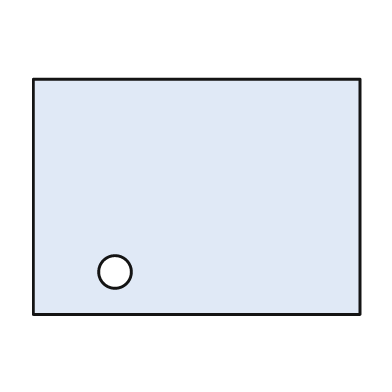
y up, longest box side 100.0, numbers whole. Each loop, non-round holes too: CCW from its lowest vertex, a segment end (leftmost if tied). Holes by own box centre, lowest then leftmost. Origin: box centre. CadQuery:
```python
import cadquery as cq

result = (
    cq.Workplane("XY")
    .moveTo(-50.0, -36.0)
    .lineTo(50.0, -36.0)
    .lineTo(50.0, 36.0)
    .lineTo(-50.0, 36.0)
    .close()
    .moveTo(-25.0, -23.0)
    .circle(5.0)
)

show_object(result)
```